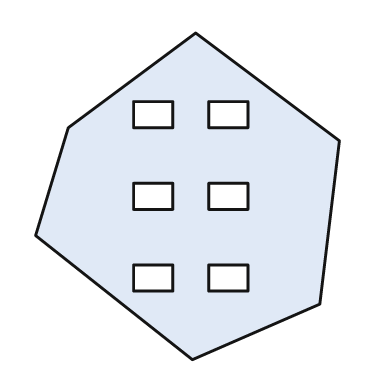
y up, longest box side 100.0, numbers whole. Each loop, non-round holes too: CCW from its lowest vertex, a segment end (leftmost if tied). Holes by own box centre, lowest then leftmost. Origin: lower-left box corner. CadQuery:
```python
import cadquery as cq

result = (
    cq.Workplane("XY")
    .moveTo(48.0, 0.0)
    .lineTo(87.0, 17.0)
    .lineTo(93.0, 67.0)
    .lineTo(49.0, 100.0)
    .lineTo(10.0, 71.0)
    .lineTo(0.0, 38.0)
    .close()
    .moveTo(30.0, 21.0)
    .lineTo(42.0, 21.0)
    .lineTo(42.0, 29.0)
    .lineTo(30.0, 29.0)
    .close()
    .moveTo(53.0, 21.0)
    .lineTo(65.0, 21.0)
    .lineTo(65.0, 29.0)
    .lineTo(53.0, 29.0)
    .close()
    .moveTo(30.0, 46.0)
    .lineTo(42.0, 46.0)
    .lineTo(42.0, 54.0)
    .lineTo(30.0, 54.0)
    .close()
    .moveTo(53.0, 46.0)
    .lineTo(65.0, 46.0)
    .lineTo(65.0, 54.0)
    .lineTo(53.0, 54.0)
    .close()
    .moveTo(30.0, 71.0)
    .lineTo(42.0, 71.0)
    .lineTo(42.0, 79.0)
    .lineTo(30.0, 79.0)
    .close()
    .moveTo(53.0, 71.0)
    .lineTo(65.0, 71.0)
    .lineTo(65.0, 79.0)
    .lineTo(53.0, 79.0)
    .close()
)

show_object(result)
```